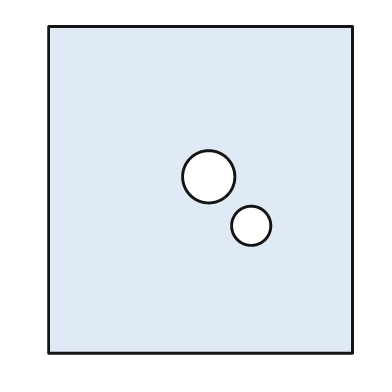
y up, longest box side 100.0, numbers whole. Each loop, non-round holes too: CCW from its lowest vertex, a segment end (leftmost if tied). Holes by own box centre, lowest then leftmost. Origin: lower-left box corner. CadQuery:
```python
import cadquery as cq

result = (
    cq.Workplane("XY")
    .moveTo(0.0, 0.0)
    .lineTo(93.0, 0.0)
    .lineTo(93.0, 100.0)
    .lineTo(0.0, 100.0)
    .close()
    .moveTo(62.0, 39.0)
    .circle(6.0)
    .moveTo(49.0, 54.0)
    .circle(8.0)
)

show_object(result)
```